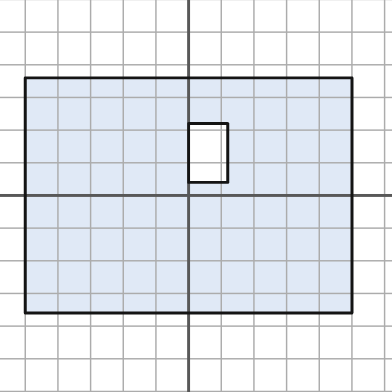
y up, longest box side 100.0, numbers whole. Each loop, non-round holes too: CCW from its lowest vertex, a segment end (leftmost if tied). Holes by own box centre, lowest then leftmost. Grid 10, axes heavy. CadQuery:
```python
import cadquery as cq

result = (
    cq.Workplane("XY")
    .moveTo(-50.0, -36.0)
    .lineTo(50.0, -36.0)
    .lineTo(50.0, 36.0)
    .lineTo(-50.0, 36.0)
    .close()
    .moveTo(0.0, 4.0)
    .lineTo(12.0, 4.0)
    .lineTo(12.0, 22.0)
    .lineTo(0.0, 22.0)
    .close()
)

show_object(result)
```